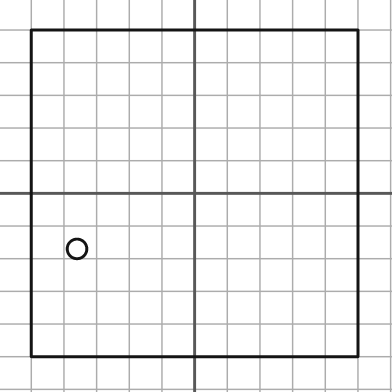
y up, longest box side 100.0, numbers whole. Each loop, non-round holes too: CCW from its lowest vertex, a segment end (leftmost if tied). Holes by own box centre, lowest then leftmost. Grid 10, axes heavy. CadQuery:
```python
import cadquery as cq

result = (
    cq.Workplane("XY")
    .moveTo(-50.0, -50.0)
    .lineTo(50.0, -50.0)
    .lineTo(50.0, 50.0)
    .lineTo(-50.0, 50.0)
    .close()
    .moveTo(-36.0, -17.0)
    .circle(3.0)
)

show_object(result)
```